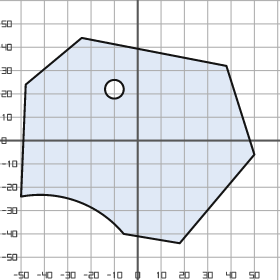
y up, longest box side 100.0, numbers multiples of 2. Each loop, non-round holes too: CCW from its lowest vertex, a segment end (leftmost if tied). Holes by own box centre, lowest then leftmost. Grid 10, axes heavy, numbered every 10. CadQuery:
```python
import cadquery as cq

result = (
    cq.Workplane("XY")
    .moveTo(18.0, -44.0)
    .lineTo(50.0, -6.0)
    .lineTo(38.0, 32.0)
    .lineTo(-24.0, 44.0)
    .lineTo(-48.0, 24.0)
    .lineTo(-50.0, -24.0)
    .threePointArc((-26.0, -26.0), (-6.0, -40.0))
    .close()
    .moveTo(-10.0, 22.0)
    .circle(4.0)
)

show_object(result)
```